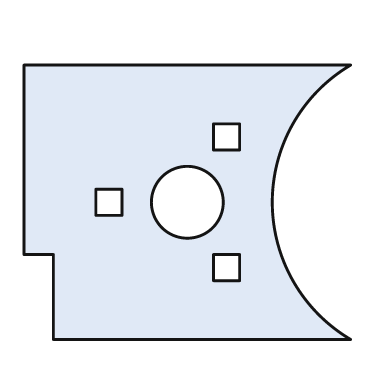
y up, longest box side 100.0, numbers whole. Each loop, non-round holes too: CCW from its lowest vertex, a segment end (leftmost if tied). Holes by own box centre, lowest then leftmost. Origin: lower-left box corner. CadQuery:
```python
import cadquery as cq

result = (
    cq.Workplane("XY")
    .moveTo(9.0, 0.0)
    .lineTo(100.0, 0.0)
    .threePointArc((76.0, 42.0), (100.0, 84.0))
    .lineTo(0.0, 84.0)
    .lineTo(0.0, 26.0)
    .lineTo(9.0, 26.0)
    .close()
    .moveTo(58.0, 18.0)
    .lineTo(66.0, 18.0)
    .lineTo(66.0, 26.0)
    .lineTo(58.0, 26.0)
    .close()
    .moveTo(22.0, 38.0)
    .lineTo(30.0, 38.0)
    .lineTo(30.0, 46.0)
    .lineTo(22.0, 46.0)
    .close()
    .moveTo(50.0, 42.0)
    .circle(11.0)
    .moveTo(58.0, 58.0)
    .lineTo(66.0, 58.0)
    .lineTo(66.0, 66.0)
    .lineTo(58.0, 66.0)
    .close()
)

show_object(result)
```